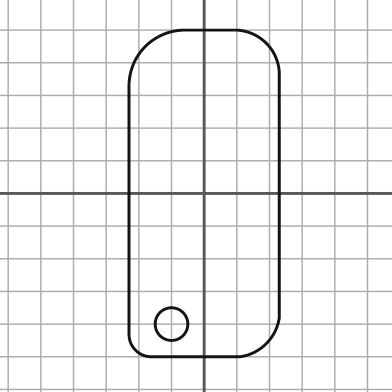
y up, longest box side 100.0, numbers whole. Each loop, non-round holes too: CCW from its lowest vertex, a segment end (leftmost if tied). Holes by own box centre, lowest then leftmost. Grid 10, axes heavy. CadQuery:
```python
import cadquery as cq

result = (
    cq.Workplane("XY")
    .moveTo(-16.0, -50.0)
    .lineTo(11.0, -50.0)
    .threePointArc((19.0, -46.0), (23.0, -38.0))
    .lineTo(23.0, 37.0)
    .threePointArc((19.0, 46.0), (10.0, 50.0))
    .lineTo(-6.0, 50.0)
    .threePointArc((-18.0, 45.0), (-23.0, 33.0))
    .lineTo(-23.0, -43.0)
    .threePointArc((-21.0, -48.0), (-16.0, -50.0))
    .close()
    .moveTo(-10.0, -40.0)
    .circle(5.0)
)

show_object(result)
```